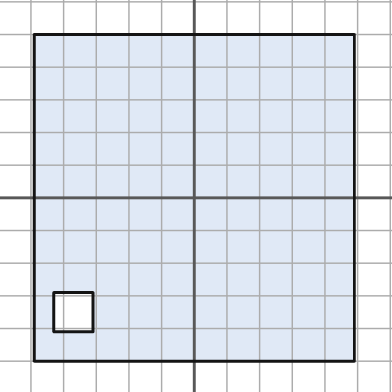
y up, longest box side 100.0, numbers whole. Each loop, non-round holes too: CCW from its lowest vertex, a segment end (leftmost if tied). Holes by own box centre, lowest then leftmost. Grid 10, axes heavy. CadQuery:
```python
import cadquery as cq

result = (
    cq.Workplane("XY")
    .moveTo(-49.0, -50.0)
    .lineTo(49.0, -50.0)
    .lineTo(49.0, 50.0)
    .lineTo(-49.0, 50.0)
    .close()
    .moveTo(-43.0, -41.0)
    .lineTo(-31.0, -41.0)
    .lineTo(-31.0, -29.0)
    .lineTo(-43.0, -29.0)
    .close()
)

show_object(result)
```